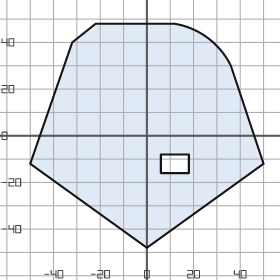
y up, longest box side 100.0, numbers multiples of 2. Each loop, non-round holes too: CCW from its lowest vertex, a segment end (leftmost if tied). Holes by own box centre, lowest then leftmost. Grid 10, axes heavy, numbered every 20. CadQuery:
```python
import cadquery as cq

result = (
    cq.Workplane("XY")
    .moveTo(0.0, -48.0)
    .lineTo(50.0, -12.0)
    .lineTo(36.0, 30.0)
    .threePointArc((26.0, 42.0), (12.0, 48.0))
    .lineTo(-22.0, 48.0)
    .lineTo(-32.0, 40.0)
    .lineTo(-50.0, -12.0)
    .close()
    .moveTo(6.0, -16.0)
    .lineTo(18.0, -16.0)
    .lineTo(18.0, -8.0)
    .lineTo(6.0, -8.0)
    .close()
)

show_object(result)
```